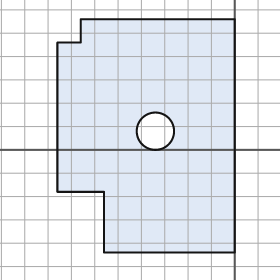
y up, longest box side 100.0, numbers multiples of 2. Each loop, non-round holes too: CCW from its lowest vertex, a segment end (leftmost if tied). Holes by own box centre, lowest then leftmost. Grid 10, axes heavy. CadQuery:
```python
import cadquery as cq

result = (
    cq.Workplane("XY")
    .moveTo(-56.0, -44.0)
    .lineTo(0.0, -44.0)
    .lineTo(0.0, 56.0)
    .lineTo(-66.0, 56.0)
    .lineTo(-66.0, 46.0)
    .lineTo(-76.0, 46.0)
    .lineTo(-76.0, -18.0)
    .lineTo(-56.0, -18.0)
    .close()
    .moveTo(-34.0, 8.0)
    .circle(8.0)
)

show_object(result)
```